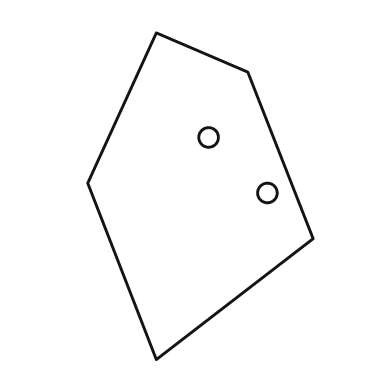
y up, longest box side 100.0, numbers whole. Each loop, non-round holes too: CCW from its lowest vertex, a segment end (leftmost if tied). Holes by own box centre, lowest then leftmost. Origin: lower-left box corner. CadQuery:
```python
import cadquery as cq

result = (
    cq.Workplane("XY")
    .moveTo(21.0, 0.0)
    .lineTo(69.0, 37.0)
    .lineTo(49.0, 88.0)
    .lineTo(21.0, 100.0)
    .lineTo(0.0, 54.0)
    .close()
    .moveTo(55.0, 51.0)
    .circle(3.0)
    .moveTo(37.0, 68.0)
    .circle(3.0)
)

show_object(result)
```